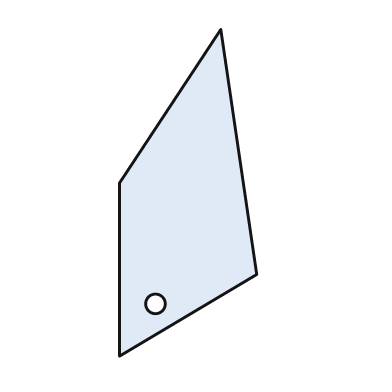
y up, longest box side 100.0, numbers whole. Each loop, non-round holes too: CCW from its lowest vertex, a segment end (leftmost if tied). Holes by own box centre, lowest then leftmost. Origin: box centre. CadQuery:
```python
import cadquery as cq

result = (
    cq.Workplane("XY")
    .moveTo(-21.0, -50.0)
    .lineTo(21.0, -25.0)
    .lineTo(10.0, 50.0)
    .lineTo(-21.0, 3.0)
    .close()
    .moveTo(-10.0, -34.0)
    .circle(3.0)
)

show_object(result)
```